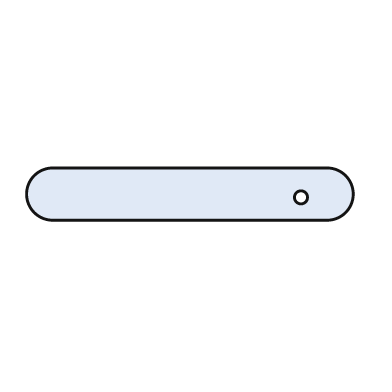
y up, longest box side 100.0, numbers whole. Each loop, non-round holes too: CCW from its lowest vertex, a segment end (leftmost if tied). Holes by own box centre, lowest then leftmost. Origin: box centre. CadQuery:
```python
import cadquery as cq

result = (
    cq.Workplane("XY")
    .moveTo(-42.0, -8.0)
    .lineTo(42.0, -8.0)
    .threePointArc((50.0, 0.0), (42.0, 8.0))
    .lineTo(-42.0, 8.0)
    .threePointArc((-50.0, 0.0), (-42.0, -8.0))
    .close()
    .moveTo(34.0, -1.0)
    .circle(2.0)
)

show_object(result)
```